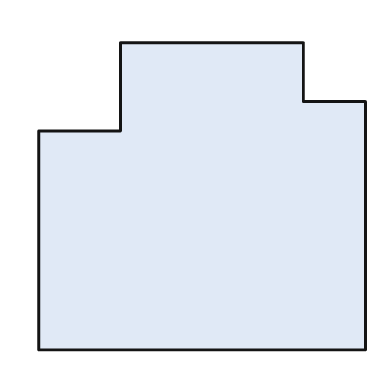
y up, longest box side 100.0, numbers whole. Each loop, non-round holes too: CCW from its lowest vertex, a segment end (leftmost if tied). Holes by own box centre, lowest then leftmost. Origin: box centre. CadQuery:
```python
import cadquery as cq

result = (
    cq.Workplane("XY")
    .moveTo(-50.0, -47.0)
    .lineTo(50.0, -47.0)
    .lineTo(50.0, 29.0)
    .lineTo(31.0, 29.0)
    .lineTo(31.0, 47.0)
    .lineTo(-25.0, 47.0)
    .lineTo(-25.0, 20.0)
    .lineTo(-50.0, 20.0)
    .close()
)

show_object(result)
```